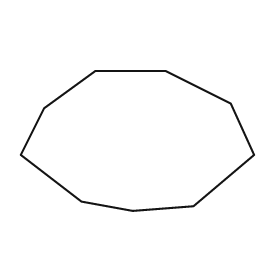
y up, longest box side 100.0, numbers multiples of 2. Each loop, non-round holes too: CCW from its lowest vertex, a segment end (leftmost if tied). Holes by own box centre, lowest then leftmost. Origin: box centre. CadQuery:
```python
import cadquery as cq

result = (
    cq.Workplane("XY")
    .moveTo(-2.0, -30.0)
    .lineTo(24.0, -28.0)
    .lineTo(50.0, -6.0)
    .lineTo(40.0, 16.0)
    .lineTo(12.0, 30.0)
    .lineTo(-18.0, 30.0)
    .lineTo(-40.0, 14.0)
    .lineTo(-50.0, -6.0)
    .lineTo(-24.0, -26.0)
    .close()
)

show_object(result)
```